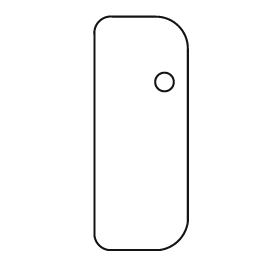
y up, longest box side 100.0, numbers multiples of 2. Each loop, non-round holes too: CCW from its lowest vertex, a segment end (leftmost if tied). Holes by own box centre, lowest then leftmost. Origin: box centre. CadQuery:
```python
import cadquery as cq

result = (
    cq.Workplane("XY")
    .moveTo(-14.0, -50.0)
    .lineTo(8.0, -50.0)
    .threePointArc((16.0, -46.0), (20.0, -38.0))
    .lineTo(20.0, 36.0)
    .threePointArc((16.0, 46.0), (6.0, 50.0))
    .lineTo(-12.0, 50.0)
    .threePointArc((-18.0, 48.0), (-20.0, 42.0))
    .lineTo(-20.0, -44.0)
    .threePointArc((-18.0, -48.0), (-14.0, -50.0))
    .close()
    .moveTo(10.0, 22.0)
    .circle(4.0)
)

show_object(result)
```